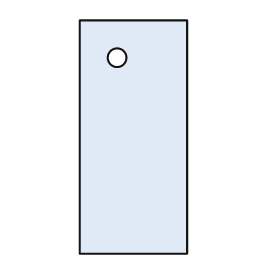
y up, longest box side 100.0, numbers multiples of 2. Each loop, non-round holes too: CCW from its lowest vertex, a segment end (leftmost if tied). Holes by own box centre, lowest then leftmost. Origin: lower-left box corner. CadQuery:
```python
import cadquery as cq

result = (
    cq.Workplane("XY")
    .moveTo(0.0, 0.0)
    .lineTo(46.0, 0.0)
    .lineTo(46.0, 100.0)
    .lineTo(0.0, 100.0)
    .close()
    .moveTo(16.0, 84.0)
    .circle(4.0)
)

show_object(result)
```